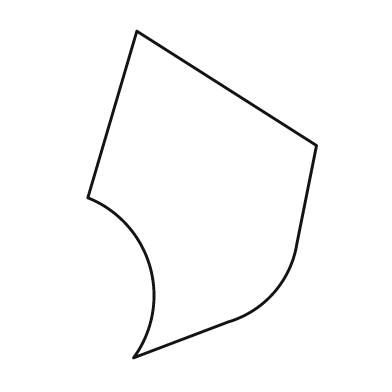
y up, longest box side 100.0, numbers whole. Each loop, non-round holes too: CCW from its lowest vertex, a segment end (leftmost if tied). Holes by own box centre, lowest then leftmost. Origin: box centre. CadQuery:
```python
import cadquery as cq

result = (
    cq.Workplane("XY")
    .moveTo(-21.0, -50.0)
    .lineTo(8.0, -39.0)
    .threePointArc((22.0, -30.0), (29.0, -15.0))
    .lineTo(35.0, 15.0)
    .lineTo(-20.0, 50.0)
    .lineTo(-35.0, -1.0)
    .threePointArc((-16.0, -22.0), (-21.0, -50.0))
    .close()
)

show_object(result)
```